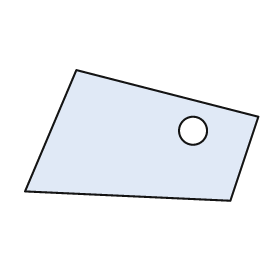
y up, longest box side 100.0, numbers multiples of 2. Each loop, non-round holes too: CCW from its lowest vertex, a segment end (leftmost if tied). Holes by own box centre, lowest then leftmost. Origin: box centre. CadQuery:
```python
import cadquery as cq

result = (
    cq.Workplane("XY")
    .moveTo(38.0, -28.0)
    .lineTo(50.0, 8.0)
    .lineTo(-28.0, 28.0)
    .lineTo(-50.0, -24.0)
    .close()
    .moveTo(22.0, 2.0)
    .circle(6.0)
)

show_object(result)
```